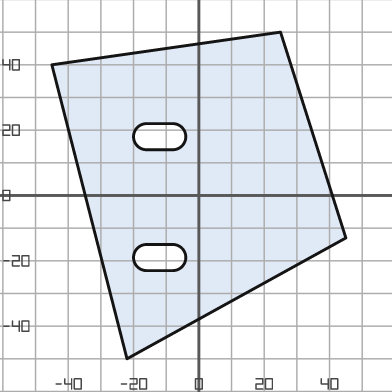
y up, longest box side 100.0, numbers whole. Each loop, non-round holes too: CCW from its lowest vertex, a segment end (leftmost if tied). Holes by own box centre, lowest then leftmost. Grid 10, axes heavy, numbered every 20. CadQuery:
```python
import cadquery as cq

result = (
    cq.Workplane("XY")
    .moveTo(-22.0, -50.0)
    .lineTo(45.0, -13.0)
    .lineTo(25.0, 50.0)
    .lineTo(-45.0, 40.0)
    .close()
    .moveTo(-16.0, -23.0)
    .lineTo(-8.0, -23.0)
    .threePointArc((-4.0, -19.0), (-8.0, -15.0))
    .lineTo(-16.0, -15.0)
    .threePointArc((-20.0, -19.0), (-16.0, -23.0))
    .close()
    .moveTo(-16.0, 14.0)
    .lineTo(-8.0, 14.0)
    .threePointArc((-4.0, 18.0), (-8.0, 22.0))
    .lineTo(-16.0, 22.0)
    .threePointArc((-20.0, 18.0), (-16.0, 14.0))
    .close()
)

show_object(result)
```